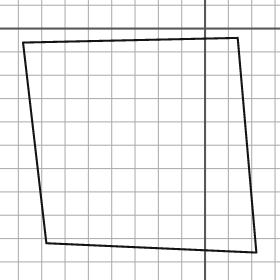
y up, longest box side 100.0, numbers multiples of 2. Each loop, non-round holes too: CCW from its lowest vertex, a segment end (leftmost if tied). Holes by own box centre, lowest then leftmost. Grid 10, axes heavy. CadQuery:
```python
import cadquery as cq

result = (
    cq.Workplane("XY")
    .moveTo(22.0, -96.0)
    .lineTo(14.0, -4.0)
    .lineTo(-78.0, -6.0)
    .lineTo(-68.0, -92.0)
    .close()
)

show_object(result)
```